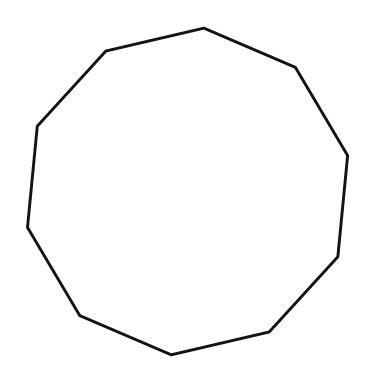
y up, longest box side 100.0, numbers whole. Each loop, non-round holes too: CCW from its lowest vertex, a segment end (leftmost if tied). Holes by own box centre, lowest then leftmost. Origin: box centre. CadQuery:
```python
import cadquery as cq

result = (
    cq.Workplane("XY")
    .moveTo(-5.0, -50.0)
    .lineTo(25.0, -43.0)
    .lineTo(46.0, -20.0)
    .lineTo(49.0, 11.0)
    .lineTo(33.0, 38.0)
    .lineTo(5.0, 50.0)
    .lineTo(-25.0, 43.0)
    .lineTo(-46.0, 20.0)
    .lineTo(-49.0, -11.0)
    .lineTo(-33.0, -38.0)
    .close()
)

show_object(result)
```